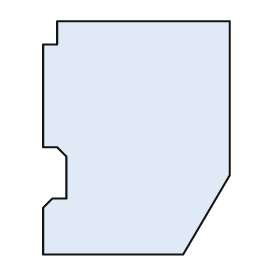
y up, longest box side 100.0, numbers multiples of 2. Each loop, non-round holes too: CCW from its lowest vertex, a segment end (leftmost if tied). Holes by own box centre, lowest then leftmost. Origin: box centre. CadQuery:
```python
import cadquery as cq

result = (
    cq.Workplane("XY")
    .moveTo(-40.0, -50.0)
    .lineTo(20.0, -50.0)
    .lineTo(40.0, -16.0)
    .lineTo(40.0, 50.0)
    .lineTo(-34.0, 50.0)
    .lineTo(-34.0, 40.0)
    .lineTo(-40.0, 40.0)
    .lineTo(-40.0, -4.0)
    .lineTo(-34.0, -4.0)
    .lineTo(-30.0, -8.0)
    .lineTo(-30.0, -26.0)
    .lineTo(-36.0, -26.0)
    .lineTo(-40.0, -30.0)
    .close()
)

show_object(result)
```